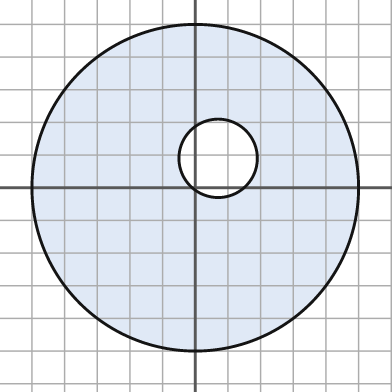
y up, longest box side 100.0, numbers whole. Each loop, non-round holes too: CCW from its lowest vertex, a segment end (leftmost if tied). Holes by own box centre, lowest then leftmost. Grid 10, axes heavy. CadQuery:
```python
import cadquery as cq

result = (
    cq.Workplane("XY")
    .moveTo(0.0, 0.0)
    .circle(50.0)
    .moveTo(7.0, 9.0)
    .circle(12.0)
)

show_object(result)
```